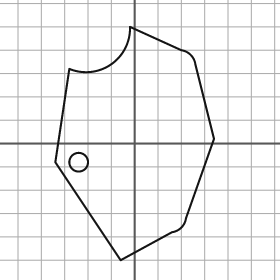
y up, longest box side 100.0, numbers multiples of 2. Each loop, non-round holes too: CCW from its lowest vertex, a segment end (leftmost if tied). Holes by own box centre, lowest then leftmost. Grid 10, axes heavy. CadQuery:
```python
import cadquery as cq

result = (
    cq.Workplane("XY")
    .moveTo(-6.0, -50.0)
    .lineTo(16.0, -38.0)
    .threePointArc((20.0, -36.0), (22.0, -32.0))
    .lineTo(34.0, 2.0)
    .lineTo(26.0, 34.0)
    .threePointArc((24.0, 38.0), (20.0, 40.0))
    .lineTo(-2.0, 50.0)
    .threePointArc((-10.0, 34.0), (-28.0, 32.0))
    .lineTo(-34.0, -8.0)
    .close()
    .moveTo(-24.0, -8.0)
    .circle(4.0)
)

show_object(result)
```